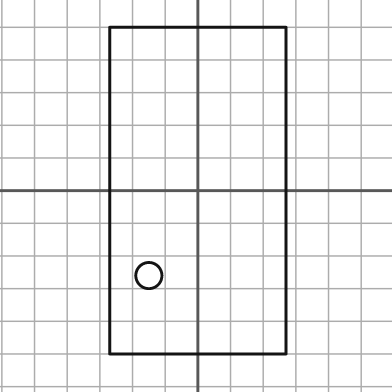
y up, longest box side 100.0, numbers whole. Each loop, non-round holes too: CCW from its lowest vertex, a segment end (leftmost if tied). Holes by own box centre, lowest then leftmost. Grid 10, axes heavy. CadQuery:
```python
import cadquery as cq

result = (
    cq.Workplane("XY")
    .moveTo(-27.0, -50.0)
    .lineTo(27.0, -50.0)
    .lineTo(27.0, 50.0)
    .lineTo(-27.0, 50.0)
    .close()
    .moveTo(-15.0, -26.0)
    .circle(4.0)
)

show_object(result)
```